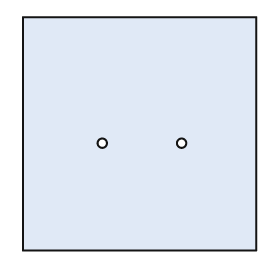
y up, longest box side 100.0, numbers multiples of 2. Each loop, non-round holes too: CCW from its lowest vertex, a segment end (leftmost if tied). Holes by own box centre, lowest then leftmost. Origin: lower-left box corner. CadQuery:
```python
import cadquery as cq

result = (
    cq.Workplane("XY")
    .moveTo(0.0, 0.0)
    .lineTo(100.0, 0.0)
    .lineTo(100.0, 100.0)
    .lineTo(0.0, 100.0)
    .close()
    .moveTo(34.0, 46.0)
    .circle(2.0)
    .moveTo(68.0, 46.0)
    .circle(2.0)
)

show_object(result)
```